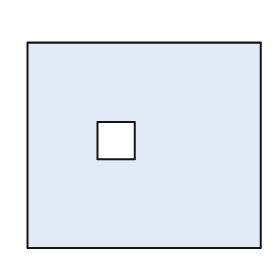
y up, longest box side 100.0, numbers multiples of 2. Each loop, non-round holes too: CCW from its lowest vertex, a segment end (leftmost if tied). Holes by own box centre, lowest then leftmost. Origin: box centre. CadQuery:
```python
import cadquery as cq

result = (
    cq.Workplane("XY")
    .moveTo(-50.0, -44.0)
    .lineTo(50.0, -44.0)
    .lineTo(50.0, 44.0)
    .lineTo(-50.0, 44.0)
    .close()
    .moveTo(-20.0, -6.0)
    .lineTo(-4.0, -6.0)
    .lineTo(-4.0, 10.0)
    .lineTo(-20.0, 10.0)
    .close()
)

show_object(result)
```